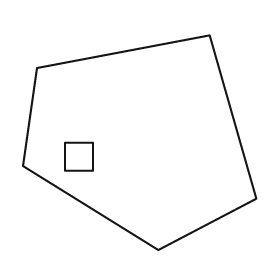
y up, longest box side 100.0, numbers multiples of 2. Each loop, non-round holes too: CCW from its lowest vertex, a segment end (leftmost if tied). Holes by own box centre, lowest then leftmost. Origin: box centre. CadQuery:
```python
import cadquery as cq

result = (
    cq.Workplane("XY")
    .moveTo(8.0, -46.0)
    .lineTo(50.0, -24.0)
    .lineTo(30.0, 46.0)
    .lineTo(-44.0, 32.0)
    .lineTo(-50.0, -10.0)
    .close()
    .moveTo(-32.0, -12.0)
    .lineTo(-20.0, -12.0)
    .lineTo(-20.0, 0.0)
    .lineTo(-32.0, 0.0)
    .close()
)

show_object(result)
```